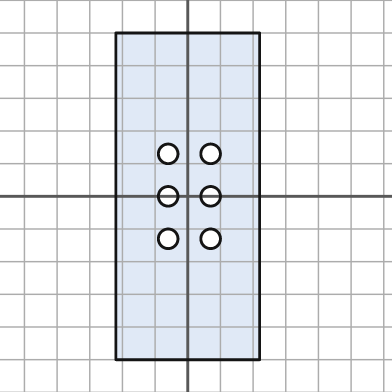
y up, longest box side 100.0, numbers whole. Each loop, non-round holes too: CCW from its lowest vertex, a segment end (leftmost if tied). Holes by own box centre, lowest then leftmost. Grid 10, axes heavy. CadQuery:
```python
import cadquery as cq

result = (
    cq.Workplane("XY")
    .moveTo(-22.0, -50.0)
    .lineTo(22.0, -50.0)
    .lineTo(22.0, 50.0)
    .lineTo(-22.0, 50.0)
    .close()
    .moveTo(-6.0, -13.0)
    .circle(3.0)
    .moveTo(7.0, -13.0)
    .circle(3.0)
    .moveTo(-6.0, 0.0)
    .circle(3.0)
    .moveTo(7.0, 0.0)
    .circle(3.0)
    .moveTo(-6.0, 13.0)
    .circle(3.0)
    .moveTo(7.0, 13.0)
    .circle(3.0)
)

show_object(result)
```